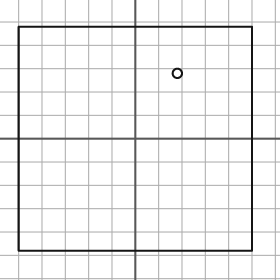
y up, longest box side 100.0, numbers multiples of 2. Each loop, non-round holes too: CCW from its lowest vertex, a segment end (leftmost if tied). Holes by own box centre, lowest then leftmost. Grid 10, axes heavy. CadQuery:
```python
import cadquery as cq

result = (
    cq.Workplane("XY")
    .moveTo(-50.0, -48.0)
    .lineTo(50.0, -48.0)
    .lineTo(50.0, 48.0)
    .lineTo(-50.0, 48.0)
    .close()
    .moveTo(18.0, 28.0)
    .circle(2.0)
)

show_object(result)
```